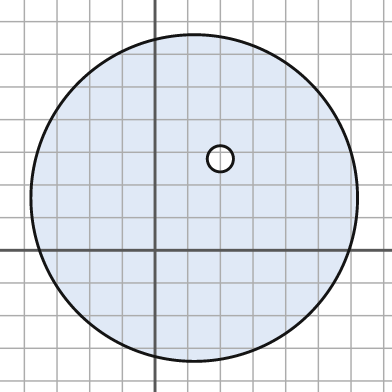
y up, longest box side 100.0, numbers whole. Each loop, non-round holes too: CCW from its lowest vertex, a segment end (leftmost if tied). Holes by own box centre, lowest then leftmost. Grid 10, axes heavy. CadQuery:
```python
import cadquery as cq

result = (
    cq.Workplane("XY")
    .moveTo(12.0, 16.0)
    .circle(50.0)
    .moveTo(20.0, 28.0)
    .circle(4.0)
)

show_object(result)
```